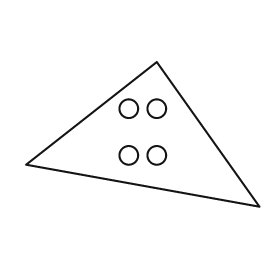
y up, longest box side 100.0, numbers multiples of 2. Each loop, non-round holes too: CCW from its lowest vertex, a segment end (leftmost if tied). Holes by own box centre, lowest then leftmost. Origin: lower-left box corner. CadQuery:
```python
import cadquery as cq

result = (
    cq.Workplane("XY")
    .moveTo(100.0, 0.0)
    .lineTo(56.0, 62.0)
    .lineTo(0.0, 18.0)
    .close()
    .moveTo(44.0, 22.0)
    .circle(4.0)
    .moveTo(56.0, 22.0)
    .circle(4.0)
    .moveTo(44.0, 42.0)
    .circle(4.0)
    .moveTo(56.0, 42.0)
    .circle(4.0)
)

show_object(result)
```